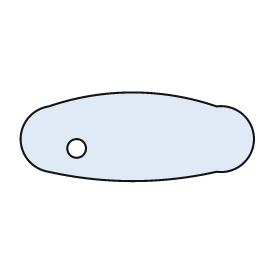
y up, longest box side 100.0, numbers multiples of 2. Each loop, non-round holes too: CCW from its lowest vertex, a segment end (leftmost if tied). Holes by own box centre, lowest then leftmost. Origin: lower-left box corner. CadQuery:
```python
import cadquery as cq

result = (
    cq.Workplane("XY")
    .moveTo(12.0, 4.0)
    .threePointArc((48.0, 0.0), (84.0, 4.0))
    .threePointArc((100.0, 18.0), (84.0, 32.0))
    .threePointArc((48.0, 38.0), (12.0, 32.0))
    .threePointArc((0.0, 18.0), (12.0, 4.0))
    .close()
    .moveTo(24.0, 14.0)
    .circle(4.0)
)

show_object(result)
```